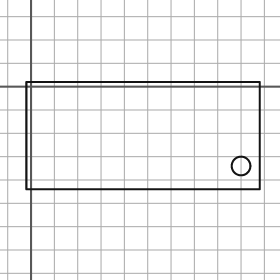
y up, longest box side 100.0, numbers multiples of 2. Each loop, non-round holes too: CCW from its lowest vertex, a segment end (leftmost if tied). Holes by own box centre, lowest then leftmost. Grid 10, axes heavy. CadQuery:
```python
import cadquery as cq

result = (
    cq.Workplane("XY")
    .moveTo(-2.0, -44.0)
    .lineTo(98.0, -44.0)
    .lineTo(98.0, 2.0)
    .lineTo(-2.0, 2.0)
    .close()
    .moveTo(90.0, -34.0)
    .circle(4.0)
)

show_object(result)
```